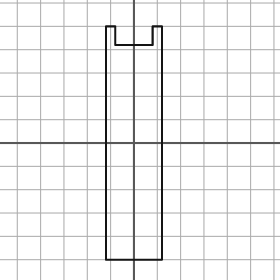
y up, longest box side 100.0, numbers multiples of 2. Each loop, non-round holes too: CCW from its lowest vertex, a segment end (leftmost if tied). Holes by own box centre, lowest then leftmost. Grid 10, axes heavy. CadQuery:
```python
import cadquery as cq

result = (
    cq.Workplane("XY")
    .moveTo(-12.0, -50.0)
    .lineTo(12.0, -50.0)
    .lineTo(12.0, 50.0)
    .lineTo(8.0, 50.0)
    .lineTo(8.0, 42.0)
    .lineTo(-8.0, 42.0)
    .lineTo(-8.0, 50.0)
    .lineTo(-12.0, 50.0)
    .close()
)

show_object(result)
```